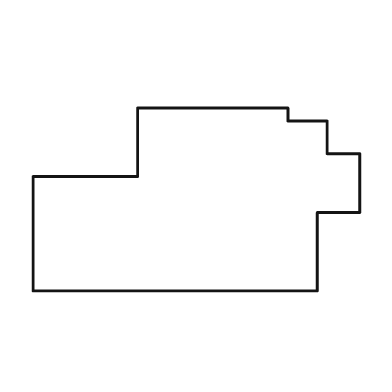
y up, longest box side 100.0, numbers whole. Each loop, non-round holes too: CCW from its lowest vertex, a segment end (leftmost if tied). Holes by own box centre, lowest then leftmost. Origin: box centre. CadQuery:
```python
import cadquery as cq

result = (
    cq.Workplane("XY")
    .moveTo(-50.0, -28.0)
    .lineTo(37.0, -28.0)
    .lineTo(37.0, -4.0)
    .lineTo(50.0, -4.0)
    .lineTo(50.0, 14.0)
    .lineTo(40.0, 14.0)
    .lineTo(40.0, 24.0)
    .lineTo(28.0, 24.0)
    .lineTo(28.0, 28.0)
    .lineTo(-18.0, 28.0)
    .lineTo(-18.0, 7.0)
    .lineTo(-50.0, 7.0)
    .close()
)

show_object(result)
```